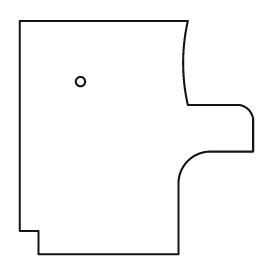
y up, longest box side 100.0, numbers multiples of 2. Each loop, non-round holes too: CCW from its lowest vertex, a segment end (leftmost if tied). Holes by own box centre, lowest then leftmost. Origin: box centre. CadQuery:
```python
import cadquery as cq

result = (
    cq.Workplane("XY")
    .moveTo(-42.0, -50.0)
    .lineTo(18.0, -50.0)
    .lineTo(18.0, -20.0)
    .threePointArc((22.0, -10.0), (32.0, -6.0))
    .lineTo(50.0, -6.0)
    .lineTo(50.0, 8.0)
    .threePointArc((48.0, 12.0), (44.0, 14.0))
    .lineTo(22.0, 14.0)
    .threePointArc((20.0, 32.0), (22.0, 50.0))
    .lineTo(-50.0, 50.0)
    .lineTo(-50.0, -40.0)
    .lineTo(-42.0, -40.0)
    .close()
    .moveTo(-24.0, 24.0)
    .circle(2.0)
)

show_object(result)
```